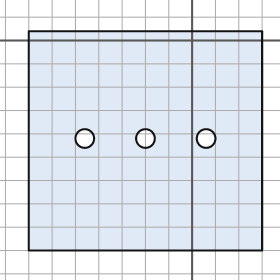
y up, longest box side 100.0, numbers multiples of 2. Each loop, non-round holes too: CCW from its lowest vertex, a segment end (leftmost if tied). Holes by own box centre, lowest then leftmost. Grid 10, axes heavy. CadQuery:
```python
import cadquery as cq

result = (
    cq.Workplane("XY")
    .moveTo(-70.0, -90.0)
    .lineTo(30.0, -90.0)
    .lineTo(30.0, 4.0)
    .lineTo(-70.0, 4.0)
    .close()
    .moveTo(-46.0, -42.0)
    .circle(4.0)
    .moveTo(-20.0, -42.0)
    .circle(4.0)
    .moveTo(6.0, -42.0)
    .circle(4.0)
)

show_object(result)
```